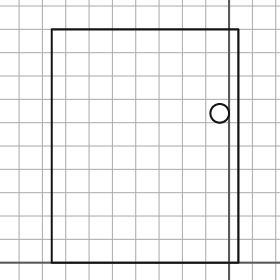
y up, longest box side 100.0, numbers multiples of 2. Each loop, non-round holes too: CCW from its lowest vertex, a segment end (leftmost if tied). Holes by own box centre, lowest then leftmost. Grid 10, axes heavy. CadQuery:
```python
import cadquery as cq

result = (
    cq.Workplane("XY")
    .moveTo(-76.0, 0.0)
    .lineTo(4.0, 0.0)
    .lineTo(4.0, 100.0)
    .lineTo(-76.0, 100.0)
    .close()
    .moveTo(-4.0, 64.0)
    .circle(4.0)
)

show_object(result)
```